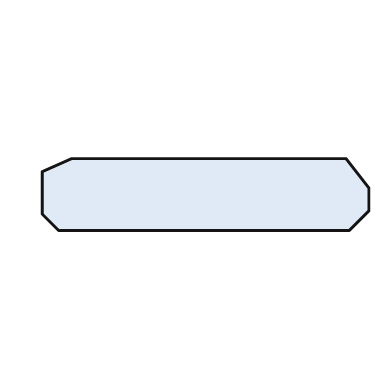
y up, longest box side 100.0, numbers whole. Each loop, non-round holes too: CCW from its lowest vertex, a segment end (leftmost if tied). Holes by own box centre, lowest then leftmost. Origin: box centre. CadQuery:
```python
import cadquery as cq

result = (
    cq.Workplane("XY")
    .moveTo(-45.0, -11.0)
    .lineTo(44.0, -11.0)
    .lineTo(50.0, -5.0)
    .lineTo(50.0, 2.0)
    .lineTo(43.0, 11.0)
    .lineTo(-41.0, 11.0)
    .lineTo(-50.0, 7.0)
    .lineTo(-50.0, -6.0)
    .close()
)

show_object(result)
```